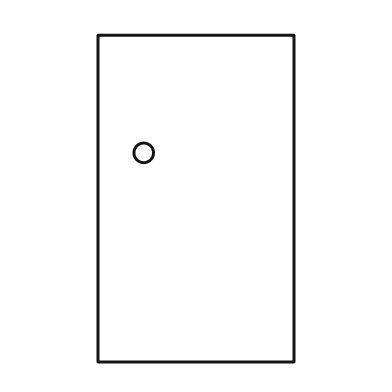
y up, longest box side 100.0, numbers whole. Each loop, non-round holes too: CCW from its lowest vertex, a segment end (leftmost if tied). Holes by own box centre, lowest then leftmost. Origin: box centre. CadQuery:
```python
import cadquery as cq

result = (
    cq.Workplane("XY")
    .moveTo(-30.0, -50.0)
    .lineTo(30.0, -50.0)
    .lineTo(30.0, 50.0)
    .lineTo(-30.0, 50.0)
    .close()
    .moveTo(-16.0, 14.0)
    .circle(3.0)
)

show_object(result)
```